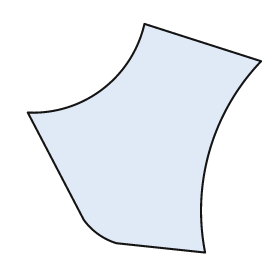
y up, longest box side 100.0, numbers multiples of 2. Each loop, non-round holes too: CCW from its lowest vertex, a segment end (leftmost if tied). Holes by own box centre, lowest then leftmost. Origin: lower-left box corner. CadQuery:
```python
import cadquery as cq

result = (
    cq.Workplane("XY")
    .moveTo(76.0, 0.0)
    .threePointArc((78.0, 44.0), (100.0, 82.0))
    .lineTo(50.0, 98.0)
    .threePointArc((32.0, 70.0), (0.0, 60.0))
    .lineTo(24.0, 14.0)
    .threePointArc((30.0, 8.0), (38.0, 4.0))
    .close()
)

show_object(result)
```